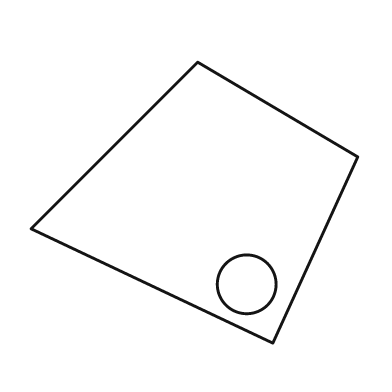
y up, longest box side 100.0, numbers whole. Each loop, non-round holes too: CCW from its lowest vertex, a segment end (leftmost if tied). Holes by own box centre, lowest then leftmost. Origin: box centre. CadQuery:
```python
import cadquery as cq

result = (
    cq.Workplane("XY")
    .moveTo(24.0, -43.0)
    .lineTo(50.0, 14.0)
    .lineTo(1.0, 43.0)
    .lineTo(-50.0, -8.0)
    .close()
    .moveTo(16.0, -25.0)
    .circle(9.0)
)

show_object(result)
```